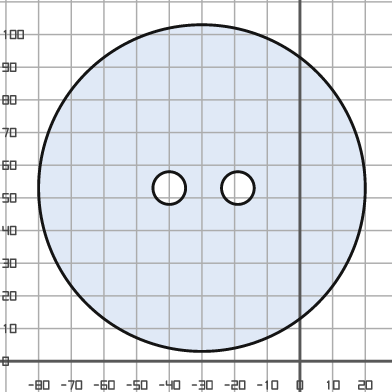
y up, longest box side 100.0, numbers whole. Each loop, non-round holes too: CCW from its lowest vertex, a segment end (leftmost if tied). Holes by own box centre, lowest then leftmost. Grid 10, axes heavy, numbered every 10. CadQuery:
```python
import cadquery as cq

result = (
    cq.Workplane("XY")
    .moveTo(-30.0, 53.0)
    .circle(50.0)
    .moveTo(-40.0, 53.0)
    .circle(5.0)
    .moveTo(-19.0, 53.0)
    .circle(5.0)
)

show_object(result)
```